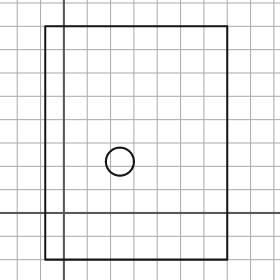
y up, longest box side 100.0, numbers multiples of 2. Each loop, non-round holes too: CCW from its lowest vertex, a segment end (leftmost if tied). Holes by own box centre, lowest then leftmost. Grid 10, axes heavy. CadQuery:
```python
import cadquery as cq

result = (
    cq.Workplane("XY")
    .moveTo(-8.0, -20.0)
    .lineTo(70.0, -20.0)
    .lineTo(70.0, 80.0)
    .lineTo(-8.0, 80.0)
    .close()
    .moveTo(24.0, 22.0)
    .circle(6.0)
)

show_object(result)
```